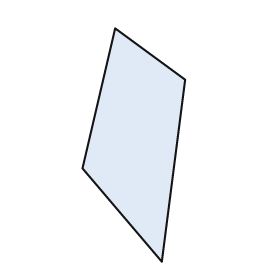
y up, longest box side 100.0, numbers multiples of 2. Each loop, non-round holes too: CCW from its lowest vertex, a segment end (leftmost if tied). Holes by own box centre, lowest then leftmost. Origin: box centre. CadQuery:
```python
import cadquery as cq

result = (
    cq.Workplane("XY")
    .moveTo(12.0, -50.0)
    .lineTo(22.0, 28.0)
    .lineTo(-8.0, 50.0)
    .lineTo(-22.0, -10.0)
    .close()
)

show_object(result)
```